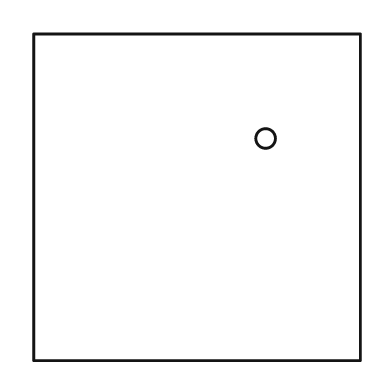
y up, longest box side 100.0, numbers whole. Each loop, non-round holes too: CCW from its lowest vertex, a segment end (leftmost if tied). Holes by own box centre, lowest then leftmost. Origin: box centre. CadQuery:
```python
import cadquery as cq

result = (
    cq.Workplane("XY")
    .moveTo(-50.0, -50.0)
    .lineTo(50.0, -50.0)
    .lineTo(50.0, 50.0)
    .lineTo(-50.0, 50.0)
    .close()
    .moveTo(21.0, 18.0)
    .circle(3.0)
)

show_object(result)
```